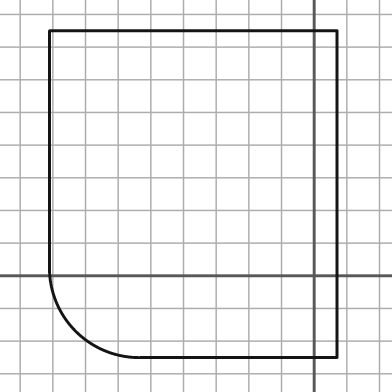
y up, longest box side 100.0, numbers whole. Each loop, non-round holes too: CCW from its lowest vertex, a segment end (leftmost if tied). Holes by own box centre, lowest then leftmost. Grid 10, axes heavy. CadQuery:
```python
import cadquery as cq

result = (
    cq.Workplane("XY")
    .moveTo(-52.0, -25.0)
    .lineTo(7.0, -25.0)
    .lineTo(7.0, 75.0)
    .lineTo(-81.0, 75.0)
    .lineTo(-81.0, 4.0)
    .threePointArc((-73.0, -17.0), (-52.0, -25.0))
    .close()
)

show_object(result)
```